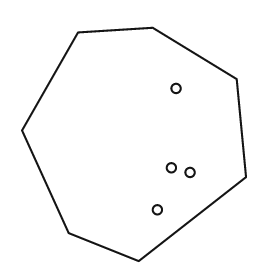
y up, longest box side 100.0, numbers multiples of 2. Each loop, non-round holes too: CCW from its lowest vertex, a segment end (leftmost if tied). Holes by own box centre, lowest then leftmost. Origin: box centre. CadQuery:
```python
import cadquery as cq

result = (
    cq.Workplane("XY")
    .moveTo(2.0, -50.0)
    .lineTo(48.0, -14.0)
    .lineTo(44.0, 28.0)
    .lineTo(8.0, 50.0)
    .lineTo(-24.0, 48.0)
    .lineTo(-48.0, 6.0)
    .lineTo(-28.0, -38.0)
    .close()
    .moveTo(10.0, -28.0)
    .circle(2.0)
    .moveTo(24.0, -12.0)
    .circle(2.0)
    .moveTo(16.0, -10.0)
    .circle(2.0)
    .moveTo(18.0, 24.0)
    .circle(2.0)
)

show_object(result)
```